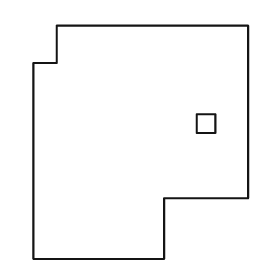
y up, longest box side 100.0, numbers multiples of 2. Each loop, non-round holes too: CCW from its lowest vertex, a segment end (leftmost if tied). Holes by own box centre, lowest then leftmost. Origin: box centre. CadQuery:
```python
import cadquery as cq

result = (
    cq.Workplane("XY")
    .moveTo(-46.0, -50.0)
    .lineTo(10.0, -50.0)
    .lineTo(10.0, -24.0)
    .lineTo(46.0, -24.0)
    .lineTo(46.0, 50.0)
    .lineTo(-36.0, 50.0)
    .lineTo(-36.0, 34.0)
    .lineTo(-46.0, 34.0)
    .close()
    .moveTo(24.0, 4.0)
    .lineTo(32.0, 4.0)
    .lineTo(32.0, 12.0)
    .lineTo(24.0, 12.0)
    .close()
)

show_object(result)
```